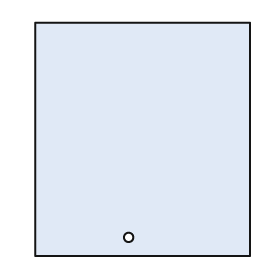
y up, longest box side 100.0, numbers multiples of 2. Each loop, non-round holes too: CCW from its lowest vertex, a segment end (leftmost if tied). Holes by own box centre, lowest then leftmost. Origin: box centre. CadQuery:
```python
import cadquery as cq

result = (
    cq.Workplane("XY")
    .moveTo(-46.0, -50.0)
    .lineTo(46.0, -50.0)
    .lineTo(46.0, 50.0)
    .lineTo(-46.0, 50.0)
    .close()
    .moveTo(-6.0, -42.0)
    .circle(2.0)
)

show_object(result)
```